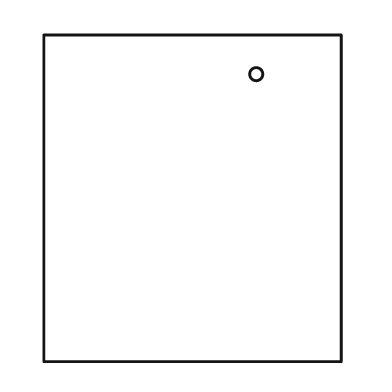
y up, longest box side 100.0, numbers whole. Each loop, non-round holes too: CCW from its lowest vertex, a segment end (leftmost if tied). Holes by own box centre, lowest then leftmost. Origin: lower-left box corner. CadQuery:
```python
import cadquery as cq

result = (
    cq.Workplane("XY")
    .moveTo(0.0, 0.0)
    .lineTo(91.0, 0.0)
    .lineTo(91.0, 100.0)
    .lineTo(0.0, 100.0)
    .close()
    .moveTo(65.0, 88.0)
    .circle(2.0)
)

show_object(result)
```